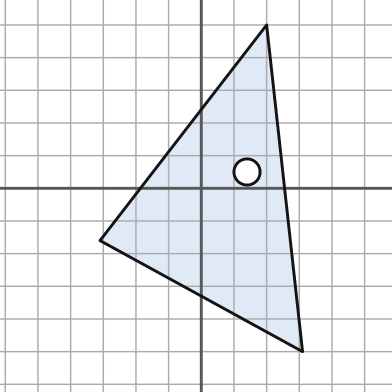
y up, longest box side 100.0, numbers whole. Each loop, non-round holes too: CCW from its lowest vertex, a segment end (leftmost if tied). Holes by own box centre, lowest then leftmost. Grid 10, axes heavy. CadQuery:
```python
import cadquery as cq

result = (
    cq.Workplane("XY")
    .moveTo(31.0, -50.0)
    .lineTo(20.0, 50.0)
    .lineTo(-31.0, -16.0)
    .close()
    .moveTo(14.0, 5.0)
    .circle(4.0)
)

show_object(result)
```